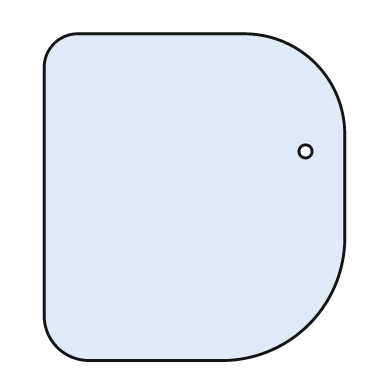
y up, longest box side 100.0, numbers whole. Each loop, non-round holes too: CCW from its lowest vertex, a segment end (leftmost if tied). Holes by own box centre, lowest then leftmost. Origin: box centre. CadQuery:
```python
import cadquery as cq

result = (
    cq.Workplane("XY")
    .moveTo(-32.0, -50.0)
    .lineTo(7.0, -50.0)
    .threePointArc((35.0, -39.0), (46.0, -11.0))
    .lineTo(46.0, 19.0)
    .threePointArc((37.0, 41.0), (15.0, 50.0))
    .lineTo(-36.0, 50.0)
    .threePointArc((-43.0, 47.0), (-46.0, 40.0))
    .lineTo(-46.0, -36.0)
    .threePointArc((-42.0, -46.0), (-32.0, -50.0))
    .close()
    .moveTo(34.0, 14.0)
    .circle(2.0)
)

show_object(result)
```